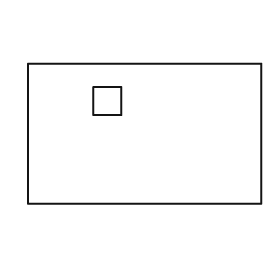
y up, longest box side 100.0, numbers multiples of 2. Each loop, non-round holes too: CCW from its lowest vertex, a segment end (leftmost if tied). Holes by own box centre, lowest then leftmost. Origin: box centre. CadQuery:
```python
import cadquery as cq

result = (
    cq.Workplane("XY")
    .moveTo(-50.0, -30.0)
    .lineTo(50.0, -30.0)
    .lineTo(50.0, 30.0)
    .lineTo(-50.0, 30.0)
    .close()
    .moveTo(-22.0, 8.0)
    .lineTo(-10.0, 8.0)
    .lineTo(-10.0, 20.0)
    .lineTo(-22.0, 20.0)
    .close()
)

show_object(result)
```